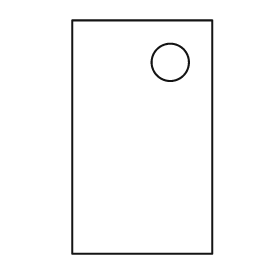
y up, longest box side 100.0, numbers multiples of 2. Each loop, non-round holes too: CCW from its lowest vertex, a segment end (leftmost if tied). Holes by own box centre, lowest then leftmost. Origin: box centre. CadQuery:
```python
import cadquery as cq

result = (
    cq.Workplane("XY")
    .moveTo(-30.0, -50.0)
    .lineTo(30.0, -50.0)
    .lineTo(30.0, 50.0)
    .lineTo(-30.0, 50.0)
    .close()
    .moveTo(12.0, 32.0)
    .circle(8.0)
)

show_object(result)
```